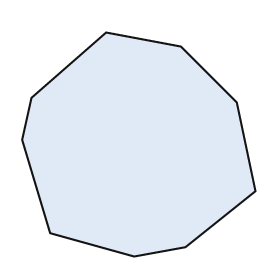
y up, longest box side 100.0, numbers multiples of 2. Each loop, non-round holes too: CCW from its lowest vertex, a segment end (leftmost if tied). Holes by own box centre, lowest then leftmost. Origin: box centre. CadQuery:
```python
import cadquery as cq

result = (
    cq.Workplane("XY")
    .moveTo(-2.0, -48.0)
    .lineTo(20.0, -44.0)
    .lineTo(50.0, -20.0)
    .lineTo(42.0, 18.0)
    .lineTo(18.0, 42.0)
    .lineTo(-14.0, 48.0)
    .lineTo(-46.0, 20.0)
    .lineTo(-50.0, 2.0)
    .lineTo(-38.0, -38.0)
    .close()
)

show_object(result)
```